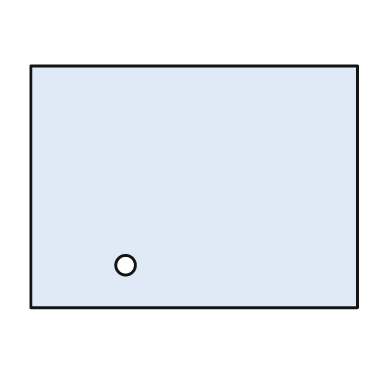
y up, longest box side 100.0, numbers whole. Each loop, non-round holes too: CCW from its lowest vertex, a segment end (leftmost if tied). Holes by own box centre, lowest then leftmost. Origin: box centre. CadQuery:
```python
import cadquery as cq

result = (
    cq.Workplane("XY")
    .moveTo(-50.0, -37.0)
    .lineTo(50.0, -37.0)
    .lineTo(50.0, 37.0)
    .lineTo(-50.0, 37.0)
    .close()
    .moveTo(-21.0, -24.0)
    .circle(3.0)
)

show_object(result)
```